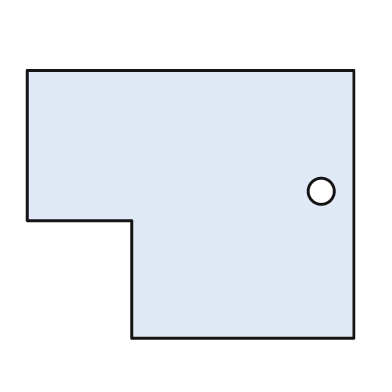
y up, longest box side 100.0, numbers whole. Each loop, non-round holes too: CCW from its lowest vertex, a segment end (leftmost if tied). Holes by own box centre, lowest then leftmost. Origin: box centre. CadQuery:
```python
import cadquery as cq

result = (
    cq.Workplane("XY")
    .moveTo(-18.0, -41.0)
    .lineTo(50.0, -41.0)
    .lineTo(50.0, 41.0)
    .lineTo(-50.0, 41.0)
    .lineTo(-50.0, -5.0)
    .lineTo(-18.0, -5.0)
    .close()
    .moveTo(40.0, 4.0)
    .circle(4.0)
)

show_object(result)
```